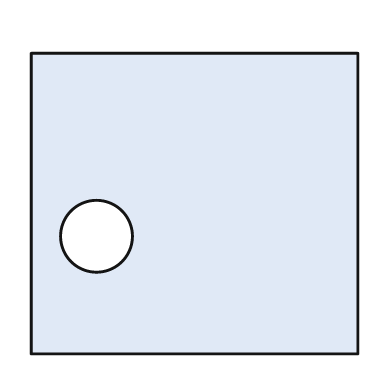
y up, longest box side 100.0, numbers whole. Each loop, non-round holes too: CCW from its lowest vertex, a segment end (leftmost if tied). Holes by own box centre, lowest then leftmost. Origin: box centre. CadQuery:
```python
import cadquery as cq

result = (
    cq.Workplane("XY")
    .moveTo(-50.0, -46.0)
    .lineTo(50.0, -46.0)
    .lineTo(50.0, 46.0)
    .lineTo(-50.0, 46.0)
    .close()
    .moveTo(-30.0, -10.0)
    .circle(11.0)
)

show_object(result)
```